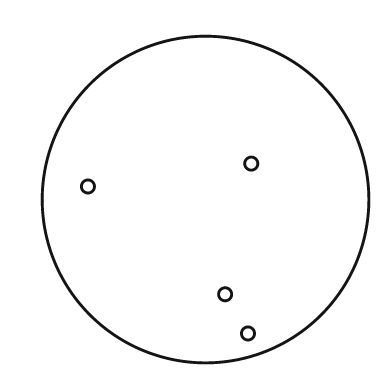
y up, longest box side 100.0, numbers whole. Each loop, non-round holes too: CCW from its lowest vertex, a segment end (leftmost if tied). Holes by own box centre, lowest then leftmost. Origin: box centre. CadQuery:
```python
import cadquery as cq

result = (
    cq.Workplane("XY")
    .moveTo(0.0, 0.0)
    .circle(50.0)
    .moveTo(13.0, -41.0)
    .circle(2.0)
    .moveTo(6.0, -29.0)
    .circle(2.0)
    .moveTo(-36.0, 4.0)
    .circle(2.0)
    .moveTo(14.0, 11.0)
    .circle(2.0)
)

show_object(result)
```